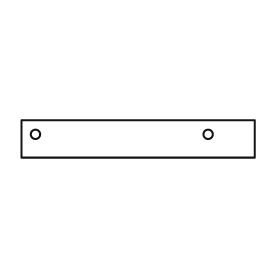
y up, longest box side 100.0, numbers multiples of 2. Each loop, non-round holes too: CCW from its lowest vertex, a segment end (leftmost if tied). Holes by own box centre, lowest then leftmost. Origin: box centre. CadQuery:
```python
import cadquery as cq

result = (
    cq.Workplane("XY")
    .moveTo(-50.0, -8.0)
    .lineTo(50.0, -8.0)
    .lineTo(50.0, 8.0)
    .lineTo(-50.0, 8.0)
    .close()
    .moveTo(-44.0, 2.0)
    .circle(2.0)
    .moveTo(30.0, 2.0)
    .circle(2.0)
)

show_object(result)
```